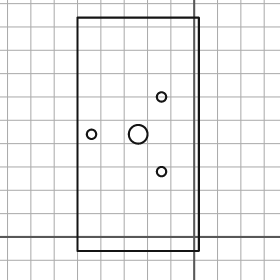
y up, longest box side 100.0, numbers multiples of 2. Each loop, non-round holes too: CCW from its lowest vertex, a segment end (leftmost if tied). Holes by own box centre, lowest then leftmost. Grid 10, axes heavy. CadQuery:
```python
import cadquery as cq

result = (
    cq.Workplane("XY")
    .moveTo(-50.0, -6.0)
    .lineTo(2.0, -6.0)
    .lineTo(2.0, 94.0)
    .lineTo(-50.0, 94.0)
    .close()
    .moveTo(-14.0, 28.0)
    .circle(2.0)
    .moveTo(-44.0, 44.0)
    .circle(2.0)
    .moveTo(-24.0, 44.0)
    .circle(4.0)
    .moveTo(-14.0, 60.0)
    .circle(2.0)
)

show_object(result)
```